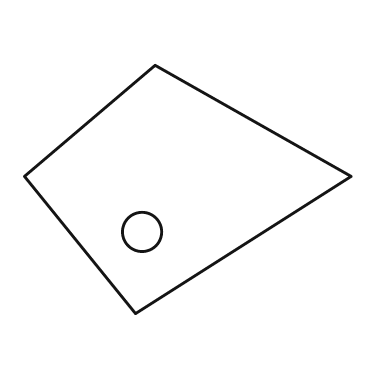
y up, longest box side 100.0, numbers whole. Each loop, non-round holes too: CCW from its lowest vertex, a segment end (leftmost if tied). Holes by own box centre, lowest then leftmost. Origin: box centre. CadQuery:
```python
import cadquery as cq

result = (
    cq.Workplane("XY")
    .moveTo(-16.0, -38.0)
    .lineTo(50.0, 4.0)
    .lineTo(-10.0, 38.0)
    .lineTo(-50.0, 4.0)
    .close()
    .moveTo(-14.0, -13.0)
    .circle(6.0)
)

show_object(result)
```